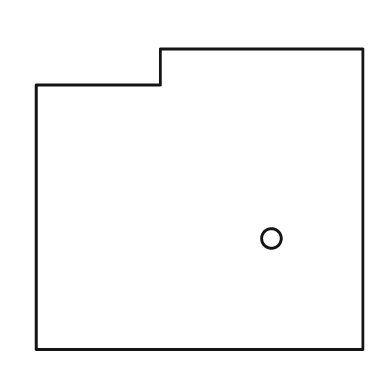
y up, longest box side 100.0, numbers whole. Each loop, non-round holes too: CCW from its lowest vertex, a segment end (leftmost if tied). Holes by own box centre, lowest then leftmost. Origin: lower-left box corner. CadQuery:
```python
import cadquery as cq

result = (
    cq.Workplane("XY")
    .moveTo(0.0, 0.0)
    .lineTo(100.0, 0.0)
    .lineTo(100.0, 92.0)
    .lineTo(38.0, 92.0)
    .lineTo(38.0, 81.0)
    .lineTo(0.0, 81.0)
    .close()
    .moveTo(72.0, 34.0)
    .circle(3.0)
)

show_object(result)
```